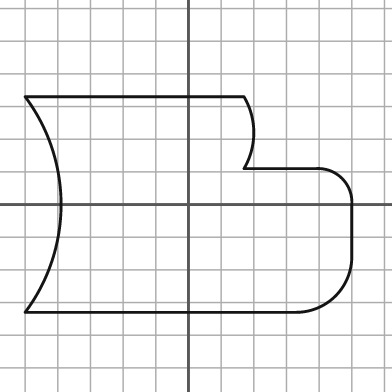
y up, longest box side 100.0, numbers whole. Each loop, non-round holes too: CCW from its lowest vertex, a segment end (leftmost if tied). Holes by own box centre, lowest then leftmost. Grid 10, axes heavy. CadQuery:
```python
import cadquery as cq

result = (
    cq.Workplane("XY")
    .moveTo(-50.0, -33.0)
    .lineTo(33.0, -33.0)
    .threePointArc((45.0, -28.0), (50.0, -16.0))
    .lineTo(50.0, 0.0)
    .threePointArc((47.0, 8.0), (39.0, 11.0))
    .lineTo(17.0, 11.0)
    .threePointArc((20.0, 22.0), (17.0, 33.0))
    .lineTo(-50.0, 33.0)
    .threePointArc((-39.0, 0.0), (-50.0, -33.0))
    .close()
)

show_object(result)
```